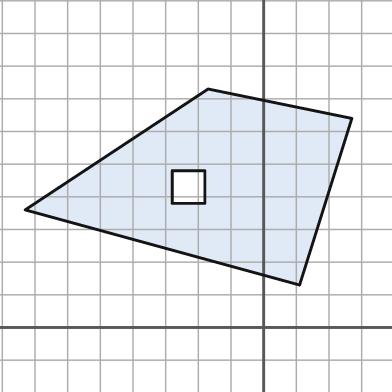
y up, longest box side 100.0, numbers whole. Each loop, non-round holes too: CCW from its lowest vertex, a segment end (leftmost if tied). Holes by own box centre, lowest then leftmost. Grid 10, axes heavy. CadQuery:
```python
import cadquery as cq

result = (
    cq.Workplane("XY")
    .moveTo(11.0, 13.0)
    .lineTo(27.0, 64.0)
    .lineTo(-17.0, 73.0)
    .lineTo(-73.0, 36.0)
    .close()
    .moveTo(-28.0, 38.0)
    .lineTo(-18.0, 38.0)
    .lineTo(-18.0, 48.0)
    .lineTo(-28.0, 48.0)
    .close()
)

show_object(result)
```